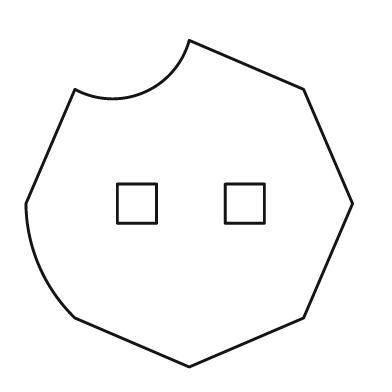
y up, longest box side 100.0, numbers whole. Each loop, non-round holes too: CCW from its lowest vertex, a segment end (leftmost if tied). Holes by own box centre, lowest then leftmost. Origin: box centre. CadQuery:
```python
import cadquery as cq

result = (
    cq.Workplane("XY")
    .moveTo(0.0, -50.0)
    .lineTo(35.0, -35.0)
    .lineTo(50.0, 0.0)
    .lineTo(35.0, 35.0)
    .lineTo(0.0, 50.0)
    .threePointArc((-14.0, 34.0), (-35.0, 35.0))
    .lineTo(-50.0, 0.0)
    .threePointArc((-46.0, -19.0), (-35.0, -35.0))
    .close()
    .moveTo(-22.0, -6.0)
    .lineTo(-10.0, -6.0)
    .lineTo(-10.0, 6.0)
    .lineTo(-22.0, 6.0)
    .close()
    .moveTo(11.0, -6.0)
    .lineTo(23.0, -6.0)
    .lineTo(23.0, 6.0)
    .lineTo(11.0, 6.0)
    .close()
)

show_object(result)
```